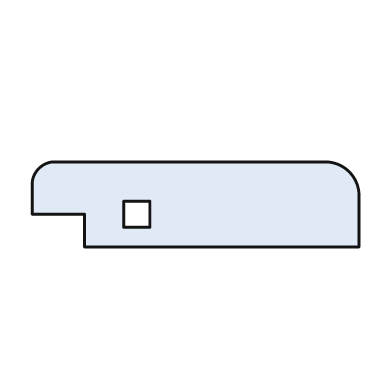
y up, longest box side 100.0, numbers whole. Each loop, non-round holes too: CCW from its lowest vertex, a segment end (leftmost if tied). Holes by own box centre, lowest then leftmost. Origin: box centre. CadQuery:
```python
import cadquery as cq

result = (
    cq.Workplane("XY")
    .moveTo(-34.0, -13.0)
    .lineTo(50.0, -13.0)
    .lineTo(50.0, 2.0)
    .threePointArc((47.0, 10.0), (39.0, 13.0))
    .lineTo(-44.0, 13.0)
    .threePointArc((-48.0, 11.0), (-50.0, 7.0))
    .lineTo(-50.0, -3.0)
    .lineTo(-34.0, -3.0)
    .close()
    .moveTo(-22.0, -7.0)
    .lineTo(-14.0, -7.0)
    .lineTo(-14.0, 1.0)
    .lineTo(-22.0, 1.0)
    .close()
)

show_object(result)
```